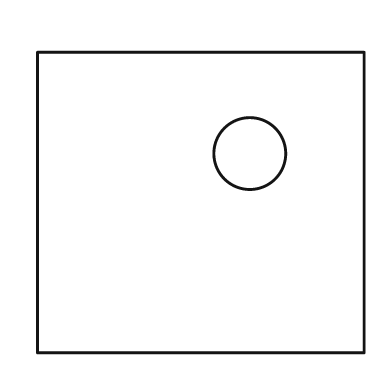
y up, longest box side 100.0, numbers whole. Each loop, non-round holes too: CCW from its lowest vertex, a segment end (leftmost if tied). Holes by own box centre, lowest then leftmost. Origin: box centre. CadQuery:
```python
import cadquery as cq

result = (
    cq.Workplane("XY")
    .moveTo(-50.0, -46.0)
    .lineTo(50.0, -46.0)
    .lineTo(50.0, 46.0)
    .lineTo(-50.0, 46.0)
    .close()
    .moveTo(15.0, 15.0)
    .circle(11.0)
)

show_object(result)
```